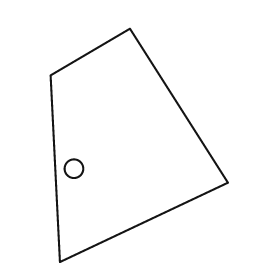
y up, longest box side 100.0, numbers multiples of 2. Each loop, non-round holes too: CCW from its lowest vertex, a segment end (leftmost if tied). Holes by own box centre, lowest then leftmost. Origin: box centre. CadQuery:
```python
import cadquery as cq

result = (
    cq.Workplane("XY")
    .moveTo(-34.0, -50.0)
    .lineTo(38.0, -16.0)
    .lineTo(-4.0, 50.0)
    .lineTo(-38.0, 30.0)
    .close()
    .moveTo(-28.0, -10.0)
    .circle(4.0)
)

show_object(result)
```